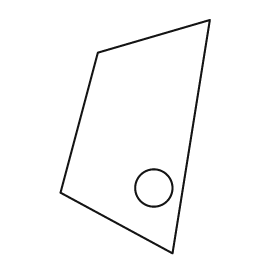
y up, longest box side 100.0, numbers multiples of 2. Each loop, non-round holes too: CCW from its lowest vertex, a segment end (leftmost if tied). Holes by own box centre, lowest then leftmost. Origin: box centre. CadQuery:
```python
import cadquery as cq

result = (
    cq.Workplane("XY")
    .moveTo(16.0, -50.0)
    .lineTo(32.0, 50.0)
    .lineTo(-16.0, 36.0)
    .lineTo(-32.0, -24.0)
    .close()
    .moveTo(8.0, -22.0)
    .circle(8.0)
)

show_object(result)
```